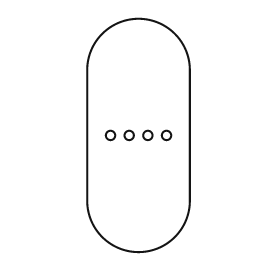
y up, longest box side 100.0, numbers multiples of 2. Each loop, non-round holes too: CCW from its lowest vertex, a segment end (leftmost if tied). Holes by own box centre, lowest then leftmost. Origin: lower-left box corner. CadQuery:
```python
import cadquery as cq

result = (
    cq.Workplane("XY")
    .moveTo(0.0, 22.0)
    .threePointArc((22.0, 0.0), (44.0, 22.0))
    .lineTo(44.0, 78.0)
    .threePointArc((22.0, 100.0), (0.0, 78.0))
    .close()
    .moveTo(10.0, 50.0)
    .circle(2.0)
    .moveTo(18.0, 50.0)
    .circle(2.0)
    .moveTo(26.0, 50.0)
    .circle(2.0)
    .moveTo(34.0, 50.0)
    .circle(2.0)
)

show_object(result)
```